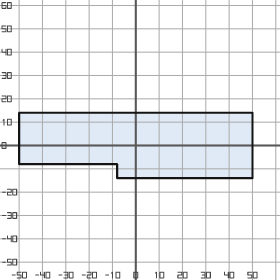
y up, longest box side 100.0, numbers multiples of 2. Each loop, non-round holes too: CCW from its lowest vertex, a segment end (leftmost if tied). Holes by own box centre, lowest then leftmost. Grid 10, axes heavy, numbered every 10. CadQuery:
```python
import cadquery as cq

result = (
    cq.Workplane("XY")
    .moveTo(-8.0, -14.0)
    .lineTo(50.0, -14.0)
    .lineTo(50.0, 14.0)
    .lineTo(-50.0, 14.0)
    .lineTo(-50.0, -8.0)
    .lineTo(-8.0, -8.0)
    .close()
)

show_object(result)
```